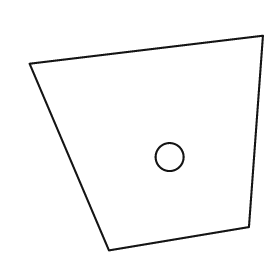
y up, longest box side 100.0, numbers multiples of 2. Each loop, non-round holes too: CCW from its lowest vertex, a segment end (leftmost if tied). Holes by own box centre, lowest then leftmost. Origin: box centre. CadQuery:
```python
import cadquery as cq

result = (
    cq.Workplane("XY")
    .moveTo(-16.0, -46.0)
    .lineTo(44.0, -36.0)
    .lineTo(50.0, 46.0)
    .lineTo(-50.0, 34.0)
    .close()
    .moveTo(10.0, -6.0)
    .circle(6.0)
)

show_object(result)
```